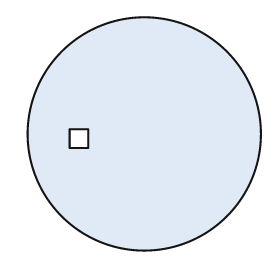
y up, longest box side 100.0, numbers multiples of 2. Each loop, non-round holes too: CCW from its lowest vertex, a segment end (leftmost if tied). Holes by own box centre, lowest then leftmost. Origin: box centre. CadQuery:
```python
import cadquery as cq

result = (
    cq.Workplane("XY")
    .moveTo(0.0, 0.0)
    .circle(50.0)
    .moveTo(-32.0, -6.0)
    .lineTo(-24.0, -6.0)
    .lineTo(-24.0, 2.0)
    .lineTo(-32.0, 2.0)
    .close()
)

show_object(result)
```